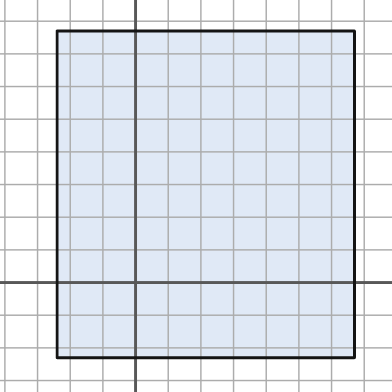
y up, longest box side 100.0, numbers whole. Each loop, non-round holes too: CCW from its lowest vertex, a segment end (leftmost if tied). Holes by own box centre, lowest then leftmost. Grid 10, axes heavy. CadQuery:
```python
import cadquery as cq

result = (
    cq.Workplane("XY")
    .moveTo(-24.0, -23.0)
    .lineTo(67.0, -23.0)
    .lineTo(67.0, 77.0)
    .lineTo(-24.0, 77.0)
    .close()
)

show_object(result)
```